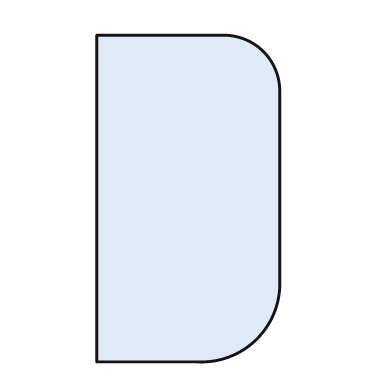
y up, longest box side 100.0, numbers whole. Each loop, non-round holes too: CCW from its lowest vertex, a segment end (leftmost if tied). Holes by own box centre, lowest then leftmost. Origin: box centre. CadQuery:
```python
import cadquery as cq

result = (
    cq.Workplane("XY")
    .moveTo(-28.0, -50.0)
    .lineTo(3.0, -50.0)
    .threePointArc((21.0, -43.0), (28.0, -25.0))
    .lineTo(28.0, 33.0)
    .threePointArc((23.0, 45.0), (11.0, 50.0))
    .lineTo(-28.0, 50.0)
    .close()
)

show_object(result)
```